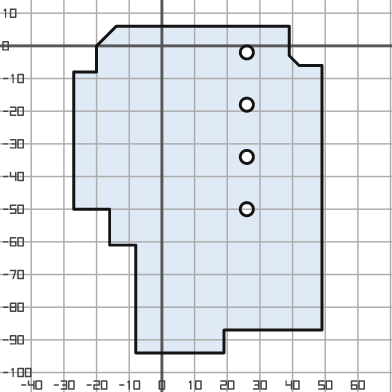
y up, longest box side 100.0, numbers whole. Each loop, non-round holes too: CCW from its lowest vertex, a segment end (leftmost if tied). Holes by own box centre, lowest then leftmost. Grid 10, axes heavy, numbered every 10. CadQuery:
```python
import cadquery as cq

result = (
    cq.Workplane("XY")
    .moveTo(-8.0, -94.0)
    .lineTo(19.0, -94.0)
    .lineTo(19.0, -87.0)
    .lineTo(49.0, -87.0)
    .lineTo(49.0, -6.0)
    .lineTo(42.0, -6.0)
    .lineTo(39.0, -3.0)
    .lineTo(39.0, 6.0)
    .lineTo(-14.0, 6.0)
    .lineTo(-20.0, 0.0)
    .lineTo(-20.0, -8.0)
    .lineTo(-27.0, -8.0)
    .lineTo(-27.0, -50.0)
    .lineTo(-16.0, -50.0)
    .lineTo(-16.0, -61.0)
    .lineTo(-8.0, -61.0)
    .close()
    .moveTo(26.0, -50.0)
    .circle(2.0)
    .moveTo(26.0, -34.0)
    .circle(2.0)
    .moveTo(26.0, -18.0)
    .circle(2.0)
    .moveTo(26.0, -2.0)
    .circle(2.0)
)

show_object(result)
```